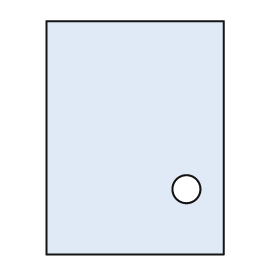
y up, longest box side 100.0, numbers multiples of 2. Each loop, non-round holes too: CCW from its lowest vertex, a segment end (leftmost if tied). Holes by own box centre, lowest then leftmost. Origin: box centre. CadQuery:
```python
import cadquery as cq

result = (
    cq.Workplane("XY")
    .moveTo(-38.0, -50.0)
    .lineTo(38.0, -50.0)
    .lineTo(38.0, 50.0)
    .lineTo(-38.0, 50.0)
    .close()
    .moveTo(22.0, -22.0)
    .circle(6.0)
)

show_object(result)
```